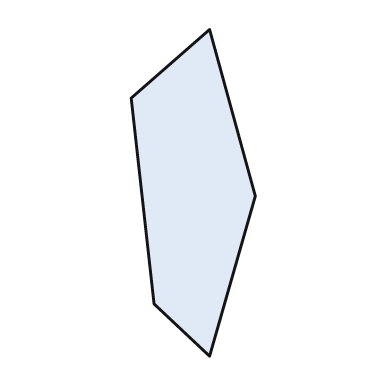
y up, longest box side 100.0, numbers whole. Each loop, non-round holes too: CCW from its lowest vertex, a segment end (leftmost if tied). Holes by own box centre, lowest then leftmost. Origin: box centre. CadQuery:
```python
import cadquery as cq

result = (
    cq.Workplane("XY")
    .moveTo(5.0, -50.0)
    .lineTo(19.0, -1.0)
    .lineTo(5.0, 50.0)
    .lineTo(-19.0, 29.0)
    .lineTo(-12.0, -34.0)
    .close()
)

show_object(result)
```